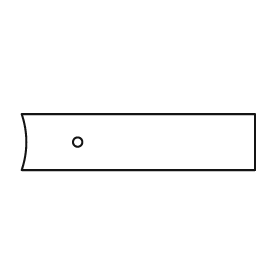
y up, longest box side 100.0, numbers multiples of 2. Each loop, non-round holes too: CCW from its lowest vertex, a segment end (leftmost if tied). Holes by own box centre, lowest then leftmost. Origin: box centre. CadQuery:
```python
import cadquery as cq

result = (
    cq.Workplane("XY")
    .moveTo(-50.0, -12.0)
    .lineTo(50.0, -12.0)
    .lineTo(50.0, 12.0)
    .lineTo(-50.0, 12.0)
    .threePointArc((-48.0, 0.0), (-50.0, -12.0))
    .close()
    .moveTo(-26.0, 0.0)
    .circle(2.0)
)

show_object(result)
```